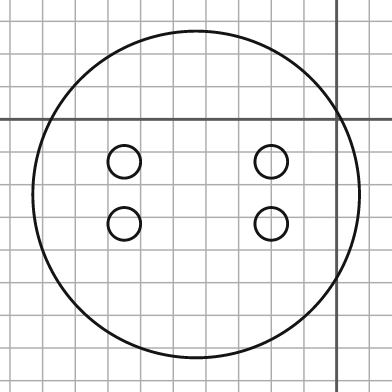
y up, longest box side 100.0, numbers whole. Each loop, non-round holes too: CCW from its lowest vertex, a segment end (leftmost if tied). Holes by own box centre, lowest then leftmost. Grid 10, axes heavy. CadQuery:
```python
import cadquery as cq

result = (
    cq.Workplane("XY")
    .moveTo(-43.0, -23.0)
    .circle(50.0)
    .moveTo(-65.0, -32.0)
    .circle(5.0)
    .moveTo(-20.0, -32.0)
    .circle(5.0)
    .moveTo(-65.0, -13.0)
    .circle(5.0)
    .moveTo(-20.0, -13.0)
    .circle(5.0)
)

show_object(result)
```